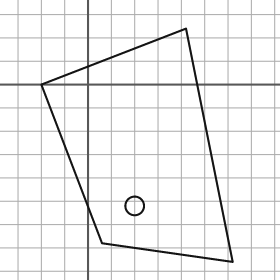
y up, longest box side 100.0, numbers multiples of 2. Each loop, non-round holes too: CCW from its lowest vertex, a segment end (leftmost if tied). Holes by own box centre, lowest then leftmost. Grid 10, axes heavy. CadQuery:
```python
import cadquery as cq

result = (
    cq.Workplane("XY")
    .moveTo(62.0, -76.0)
    .lineTo(42.0, 24.0)
    .lineTo(-20.0, 0.0)
    .lineTo(6.0, -68.0)
    .close()
    .moveTo(20.0, -52.0)
    .circle(4.0)
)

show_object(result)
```